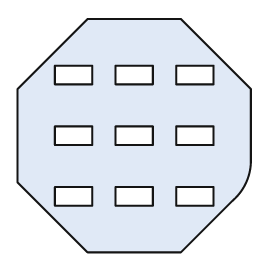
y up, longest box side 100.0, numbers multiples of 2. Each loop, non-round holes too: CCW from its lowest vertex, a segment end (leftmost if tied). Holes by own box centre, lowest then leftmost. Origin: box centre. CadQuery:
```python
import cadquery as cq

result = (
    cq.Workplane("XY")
    .moveTo(-20.0, -50.0)
    .lineTo(20.0, -50.0)
    .lineTo(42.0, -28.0)
    .threePointArc((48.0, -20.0), (50.0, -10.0))
    .lineTo(50.0, 20.0)
    .lineTo(20.0, 50.0)
    .lineTo(-20.0, 50.0)
    .lineTo(-50.0, 20.0)
    .lineTo(-50.0, -20.0)
    .close()
    .moveTo(-34.0, -30.0)
    .lineTo(-18.0, -30.0)
    .lineTo(-18.0, -22.0)
    .lineTo(-34.0, -22.0)
    .close()
    .moveTo(-8.0, -30.0)
    .lineTo(8.0, -30.0)
    .lineTo(8.0, -22.0)
    .lineTo(-8.0, -22.0)
    .close()
    .moveTo(18.0, -30.0)
    .lineTo(34.0, -30.0)
    .lineTo(34.0, -22.0)
    .lineTo(18.0, -22.0)
    .close()
    .moveTo(-34.0, -4.0)
    .lineTo(-18.0, -4.0)
    .lineTo(-18.0, 4.0)
    .lineTo(-34.0, 4.0)
    .close()
    .moveTo(-8.0, -4.0)
    .lineTo(8.0, -4.0)
    .lineTo(8.0, 4.0)
    .lineTo(-8.0, 4.0)
    .close()
    .moveTo(18.0, -4.0)
    .lineTo(34.0, -4.0)
    .lineTo(34.0, 4.0)
    .lineTo(18.0, 4.0)
    .close()
    .moveTo(-34.0, 22.0)
    .lineTo(-18.0, 22.0)
    .lineTo(-18.0, 30.0)
    .lineTo(-34.0, 30.0)
    .close()
    .moveTo(-8.0, 22.0)
    .lineTo(8.0, 22.0)
    .lineTo(8.0, 30.0)
    .lineTo(-8.0, 30.0)
    .close()
    .moveTo(18.0, 22.0)
    .lineTo(34.0, 22.0)
    .lineTo(34.0, 30.0)
    .lineTo(18.0, 30.0)
    .close()
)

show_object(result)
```